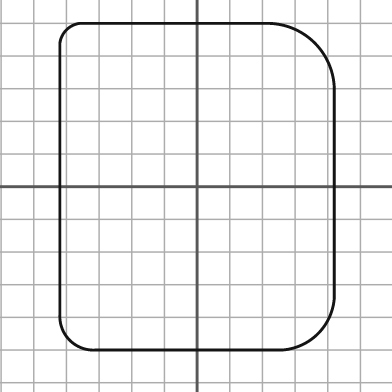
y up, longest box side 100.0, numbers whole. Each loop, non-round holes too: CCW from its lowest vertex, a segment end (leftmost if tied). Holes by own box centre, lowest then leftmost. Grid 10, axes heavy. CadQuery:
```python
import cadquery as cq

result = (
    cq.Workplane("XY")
    .moveTo(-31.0, -50.0)
    .lineTo(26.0, -50.0)
    .threePointArc((37.0, -45.0), (42.0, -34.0))
    .lineTo(42.0, 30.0)
    .threePointArc((36.0, 44.0), (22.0, 50.0))
    .lineTo(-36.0, 50.0)
    .threePointArc((-40.0, 48.0), (-42.0, 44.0))
    .lineTo(-42.0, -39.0)
    .threePointArc((-39.0, -47.0), (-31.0, -50.0))
    .close()
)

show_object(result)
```